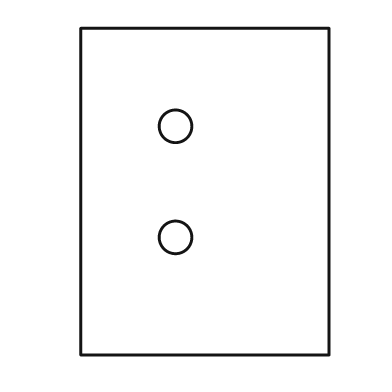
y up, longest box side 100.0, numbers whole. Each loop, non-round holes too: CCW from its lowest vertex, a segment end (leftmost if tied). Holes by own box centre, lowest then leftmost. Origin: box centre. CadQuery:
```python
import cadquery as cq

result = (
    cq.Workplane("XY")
    .moveTo(-38.0, -50.0)
    .lineTo(38.0, -50.0)
    .lineTo(38.0, 50.0)
    .lineTo(-38.0, 50.0)
    .close()
    .moveTo(-9.0, -14.0)
    .circle(5.0)
    .moveTo(-9.0, 20.0)
    .circle(5.0)
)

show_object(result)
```